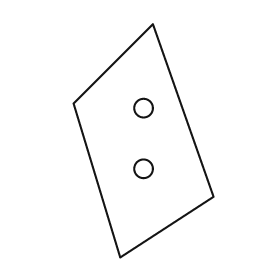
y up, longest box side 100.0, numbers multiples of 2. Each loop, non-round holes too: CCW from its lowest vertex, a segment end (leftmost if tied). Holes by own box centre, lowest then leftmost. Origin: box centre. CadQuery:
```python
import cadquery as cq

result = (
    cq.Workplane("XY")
    .moveTo(-10.0, -50.0)
    .lineTo(30.0, -24.0)
    .lineTo(4.0, 50.0)
    .lineTo(-30.0, 16.0)
    .close()
    .moveTo(0.0, -12.0)
    .circle(4.0)
    .moveTo(0.0, 14.0)
    .circle(4.0)
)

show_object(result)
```